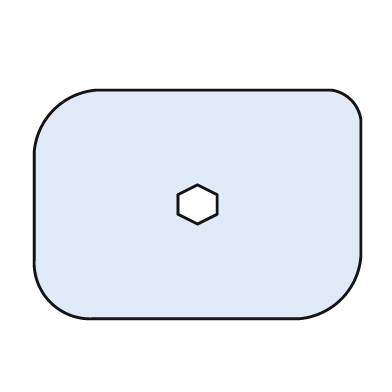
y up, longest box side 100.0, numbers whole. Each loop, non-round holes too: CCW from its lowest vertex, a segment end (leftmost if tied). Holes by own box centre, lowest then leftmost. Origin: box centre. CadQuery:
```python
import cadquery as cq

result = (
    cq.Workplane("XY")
    .moveTo(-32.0, -35.0)
    .lineTo(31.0, -35.0)
    .threePointArc((44.0, -29.0), (50.0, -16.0))
    .lineTo(50.0, 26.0)
    .threePointArc((47.0, 32.0), (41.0, 35.0))
    .lineTo(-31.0, 35.0)
    .threePointArc((-44.0, 29.0), (-50.0, 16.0))
    .lineTo(-50.0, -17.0)
    .threePointArc((-45.0, -30.0), (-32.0, -35.0))
    .close()
    .moveTo(0.0, -6.0)
    .lineTo(6.0, -3.0)
    .lineTo(6.0, 3.0)
    .lineTo(0.0, 6.0)
    .lineTo(-6.0, 3.0)
    .lineTo(-6.0, -3.0)
    .close()
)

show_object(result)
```